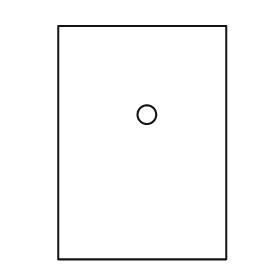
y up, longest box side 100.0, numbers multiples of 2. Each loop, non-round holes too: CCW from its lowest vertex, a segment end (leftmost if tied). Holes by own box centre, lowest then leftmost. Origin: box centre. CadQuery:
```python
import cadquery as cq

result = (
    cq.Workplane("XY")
    .moveTo(-36.0, -50.0)
    .lineTo(36.0, -50.0)
    .lineTo(36.0, 50.0)
    .lineTo(-36.0, 50.0)
    .close()
    .moveTo(2.0, 12.0)
    .circle(4.0)
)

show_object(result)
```